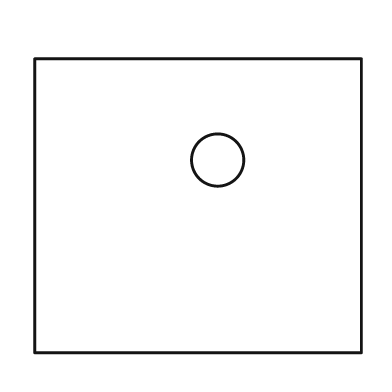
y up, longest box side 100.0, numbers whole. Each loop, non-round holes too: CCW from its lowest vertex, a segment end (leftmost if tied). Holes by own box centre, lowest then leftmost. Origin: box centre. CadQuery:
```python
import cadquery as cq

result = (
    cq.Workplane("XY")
    .moveTo(-50.0, -45.0)
    .lineTo(50.0, -45.0)
    .lineTo(50.0, 45.0)
    .lineTo(-50.0, 45.0)
    .close()
    .moveTo(6.0, 14.0)
    .circle(8.0)
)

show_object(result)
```